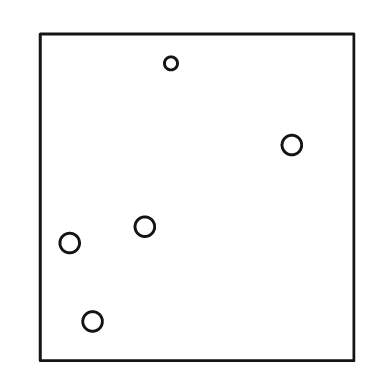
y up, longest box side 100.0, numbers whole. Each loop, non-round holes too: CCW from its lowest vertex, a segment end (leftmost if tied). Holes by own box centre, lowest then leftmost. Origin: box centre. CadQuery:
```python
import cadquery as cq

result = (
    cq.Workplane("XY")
    .moveTo(-48.0, -50.0)
    .lineTo(48.0, -50.0)
    .lineTo(48.0, 50.0)
    .lineTo(-48.0, 50.0)
    .close()
    .moveTo(-32.0, -38.0)
    .circle(3.0)
    .moveTo(-39.0, -14.0)
    .circle(3.0)
    .moveTo(-16.0, -9.0)
    .circle(3.0)
    .moveTo(29.0, 16.0)
    .circle(3.0)
    .moveTo(-8.0, 41.0)
    .circle(2.0)
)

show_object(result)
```